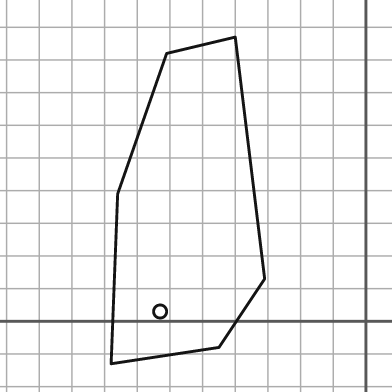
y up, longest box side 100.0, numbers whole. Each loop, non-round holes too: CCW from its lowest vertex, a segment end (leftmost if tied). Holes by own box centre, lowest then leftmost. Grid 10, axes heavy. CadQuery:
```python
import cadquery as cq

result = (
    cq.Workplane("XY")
    .moveTo(-78.0, -13.0)
    .lineTo(-45.0, -8.0)
    .lineTo(-31.0, 13.0)
    .lineTo(-40.0, 87.0)
    .lineTo(-61.0, 82.0)
    .lineTo(-76.0, 39.0)
    .close()
    .moveTo(-63.0, 3.0)
    .circle(2.0)
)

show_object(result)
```